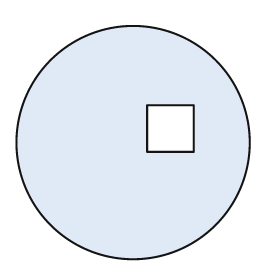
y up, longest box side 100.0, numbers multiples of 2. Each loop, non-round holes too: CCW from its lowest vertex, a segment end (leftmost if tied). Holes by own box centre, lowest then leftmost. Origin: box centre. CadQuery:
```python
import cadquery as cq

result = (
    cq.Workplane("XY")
    .moveTo(0.0, 0.0)
    .circle(50.0)
    .moveTo(6.0, -4.0)
    .lineTo(26.0, -4.0)
    .lineTo(26.0, 16.0)
    .lineTo(6.0, 16.0)
    .close()
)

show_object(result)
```